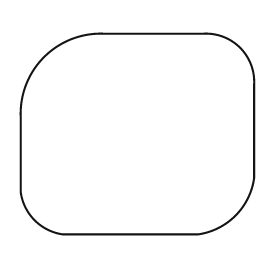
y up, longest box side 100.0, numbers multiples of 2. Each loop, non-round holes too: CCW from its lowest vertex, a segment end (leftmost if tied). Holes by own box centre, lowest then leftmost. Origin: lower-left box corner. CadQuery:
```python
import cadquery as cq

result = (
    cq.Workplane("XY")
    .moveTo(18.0, 0.0)
    .lineTo(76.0, 0.0)
    .threePointArc((92.0, 8.0), (100.0, 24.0))
    .lineTo(100.0, 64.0)
    .threePointArc((94.0, 80.0), (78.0, 86.0))
    .lineTo(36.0, 86.0)
    .threePointArc((10.0, 76.0), (0.0, 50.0))
    .lineTo(0.0, 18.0)
    .threePointArc((6.0, 6.0), (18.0, 0.0))
    .close()
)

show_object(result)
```